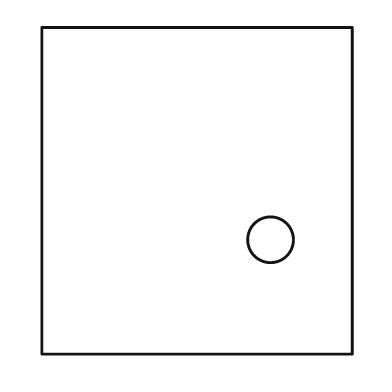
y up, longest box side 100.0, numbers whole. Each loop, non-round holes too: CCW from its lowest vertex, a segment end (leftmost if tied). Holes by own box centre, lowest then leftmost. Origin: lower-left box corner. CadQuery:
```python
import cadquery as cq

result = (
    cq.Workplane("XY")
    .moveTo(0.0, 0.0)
    .lineTo(95.0, 0.0)
    .lineTo(95.0, 100.0)
    .lineTo(0.0, 100.0)
    .close()
    .moveTo(70.0, 35.0)
    .circle(7.0)
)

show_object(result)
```